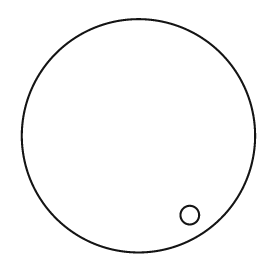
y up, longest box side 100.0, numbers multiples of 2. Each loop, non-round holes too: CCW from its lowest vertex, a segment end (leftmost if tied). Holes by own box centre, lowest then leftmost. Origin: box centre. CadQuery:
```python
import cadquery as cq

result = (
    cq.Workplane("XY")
    .moveTo(0.0, 0.0)
    .circle(50.0)
    .moveTo(22.0, -34.0)
    .circle(4.0)
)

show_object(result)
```